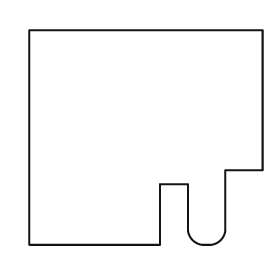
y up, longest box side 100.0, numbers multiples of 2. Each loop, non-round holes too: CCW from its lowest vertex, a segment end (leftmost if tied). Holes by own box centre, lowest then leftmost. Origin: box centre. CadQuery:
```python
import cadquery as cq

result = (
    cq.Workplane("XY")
    .moveTo(-50.0, -46.0)
    .lineTo(6.0, -46.0)
    .lineTo(6.0, -20.0)
    .lineTo(18.0, -20.0)
    .lineTo(18.0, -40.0)
    .threePointArc((20.0, -44.0), (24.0, -46.0))
    .lineTo(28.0, -46.0)
    .threePointArc((32.0, -44.0), (34.0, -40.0))
    .lineTo(34.0, -14.0)
    .lineTo(50.0, -14.0)
    .lineTo(50.0, 46.0)
    .lineTo(-50.0, 46.0)
    .close()
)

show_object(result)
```